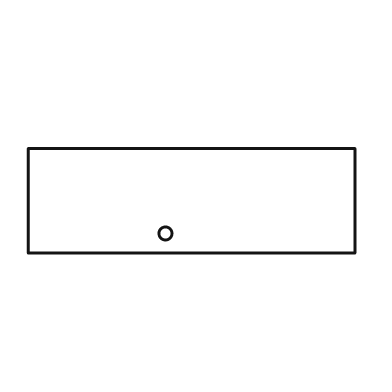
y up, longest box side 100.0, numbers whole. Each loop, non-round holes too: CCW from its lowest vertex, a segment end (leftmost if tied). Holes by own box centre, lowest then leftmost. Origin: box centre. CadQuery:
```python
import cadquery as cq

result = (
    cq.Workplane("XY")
    .moveTo(-50.0, -16.0)
    .lineTo(50.0, -16.0)
    .lineTo(50.0, 16.0)
    .lineTo(-50.0, 16.0)
    .close()
    .moveTo(-8.0, -10.0)
    .circle(2.0)
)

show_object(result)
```